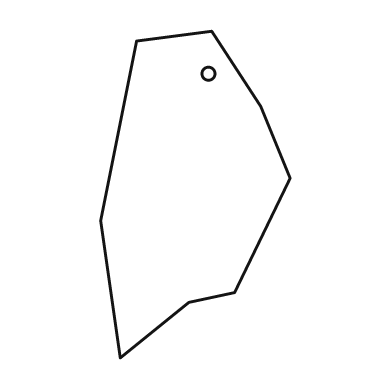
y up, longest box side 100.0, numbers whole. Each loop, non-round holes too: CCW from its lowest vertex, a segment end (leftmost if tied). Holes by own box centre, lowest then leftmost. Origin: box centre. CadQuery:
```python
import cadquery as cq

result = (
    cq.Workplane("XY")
    .moveTo(-23.0, -50.0)
    .lineTo(-2.0, -33.0)
    .lineTo(12.0, -30.0)
    .lineTo(29.0, 5.0)
    .lineTo(20.0, 27.0)
    .lineTo(5.0, 50.0)
    .lineTo(-18.0, 47.0)
    .lineTo(-29.0, -8.0)
    .close()
    .moveTo(4.0, 37.0)
    .circle(2.0)
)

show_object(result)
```